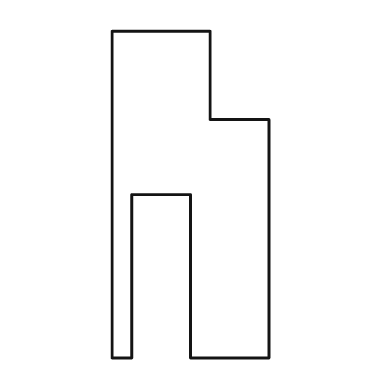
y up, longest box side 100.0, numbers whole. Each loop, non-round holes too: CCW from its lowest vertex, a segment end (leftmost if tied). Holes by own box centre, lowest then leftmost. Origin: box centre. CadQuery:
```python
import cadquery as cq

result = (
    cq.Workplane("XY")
    .moveTo(-24.0, -50.0)
    .lineTo(-18.0, -50.0)
    .lineTo(-18.0, 0.0)
    .lineTo(0.0, 0.0)
    .lineTo(0.0, -50.0)
    .lineTo(24.0, -50.0)
    .lineTo(24.0, 23.0)
    .lineTo(6.0, 23.0)
    .lineTo(6.0, 50.0)
    .lineTo(-24.0, 50.0)
    .close()
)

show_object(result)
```